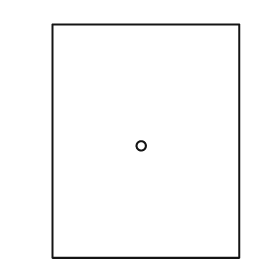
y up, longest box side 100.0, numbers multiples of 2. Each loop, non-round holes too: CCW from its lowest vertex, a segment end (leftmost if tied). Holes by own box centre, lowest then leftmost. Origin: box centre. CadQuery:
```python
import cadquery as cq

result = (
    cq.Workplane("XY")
    .moveTo(-40.0, -50.0)
    .lineTo(40.0, -50.0)
    .lineTo(40.0, 50.0)
    .lineTo(-40.0, 50.0)
    .close()
    .moveTo(-2.0, -2.0)
    .circle(2.0)
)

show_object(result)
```